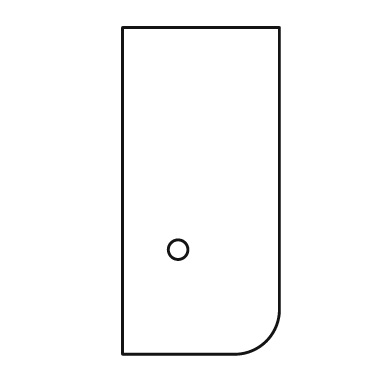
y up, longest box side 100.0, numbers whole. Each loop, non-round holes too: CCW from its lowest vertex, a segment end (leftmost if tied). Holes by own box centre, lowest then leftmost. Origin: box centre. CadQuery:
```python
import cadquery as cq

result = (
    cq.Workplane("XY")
    .moveTo(-24.0, -50.0)
    .lineTo(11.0, -50.0)
    .threePointArc((20.0, -46.0), (24.0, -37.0))
    .lineTo(24.0, 50.0)
    .lineTo(-24.0, 50.0)
    .close()
    .moveTo(-7.0, -18.0)
    .circle(3.0)
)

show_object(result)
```